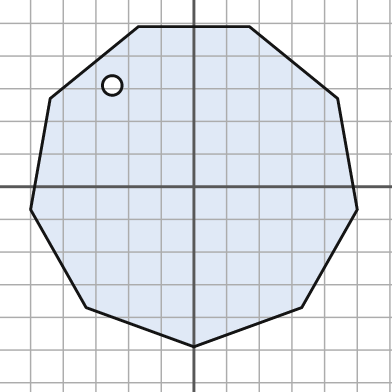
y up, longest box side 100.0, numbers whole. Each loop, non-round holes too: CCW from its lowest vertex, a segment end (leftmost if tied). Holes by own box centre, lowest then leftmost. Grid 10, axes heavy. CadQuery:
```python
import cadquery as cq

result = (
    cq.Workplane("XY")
    .moveTo(0.0, -49.0)
    .lineTo(33.0, -37.0)
    .lineTo(50.0, -7.0)
    .lineTo(44.0, 27.0)
    .lineTo(17.0, 49.0)
    .lineTo(-17.0, 49.0)
    .lineTo(-44.0, 27.0)
    .lineTo(-50.0, -7.0)
    .lineTo(-33.0, -37.0)
    .close()
    .moveTo(-25.0, 31.0)
    .circle(3.0)
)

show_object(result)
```